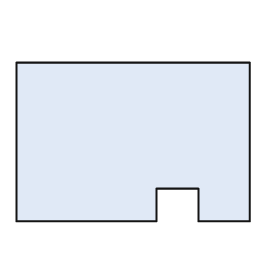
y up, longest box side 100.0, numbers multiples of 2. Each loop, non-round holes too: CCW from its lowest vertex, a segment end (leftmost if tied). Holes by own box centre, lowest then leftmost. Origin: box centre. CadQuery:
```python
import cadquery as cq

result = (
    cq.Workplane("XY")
    .moveTo(-50.0, -34.0)
    .lineTo(10.0, -34.0)
    .lineTo(10.0, -20.0)
    .lineTo(28.0, -20.0)
    .lineTo(28.0, -34.0)
    .lineTo(50.0, -34.0)
    .lineTo(50.0, 34.0)
    .lineTo(-50.0, 34.0)
    .close()
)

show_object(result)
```